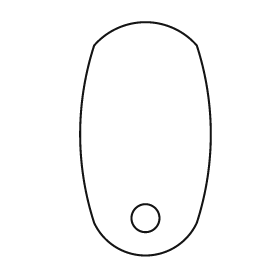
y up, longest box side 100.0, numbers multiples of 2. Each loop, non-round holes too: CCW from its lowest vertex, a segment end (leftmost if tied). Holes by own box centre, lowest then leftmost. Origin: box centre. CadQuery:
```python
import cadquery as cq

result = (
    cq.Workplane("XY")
    .moveTo(-22.0, -36.0)
    .threePointArc((0.0, -50.0), (22.0, -36.0))
    .threePointArc((28.0, 2.0), (22.0, 40.0))
    .threePointArc((0.0, 50.0), (-22.0, 40.0))
    .threePointArc((-28.0, 2.0), (-22.0, -36.0))
    .close()
    .moveTo(0.0, -34.0)
    .circle(6.0)
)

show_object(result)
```